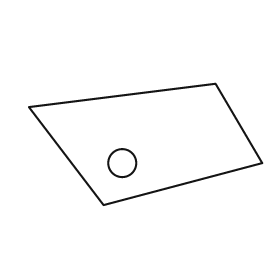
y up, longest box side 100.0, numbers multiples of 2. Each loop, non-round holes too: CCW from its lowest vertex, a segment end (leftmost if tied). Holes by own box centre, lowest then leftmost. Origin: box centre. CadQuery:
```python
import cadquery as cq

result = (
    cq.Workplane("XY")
    .moveTo(-18.0, -26.0)
    .lineTo(50.0, -8.0)
    .lineTo(30.0, 26.0)
    .lineTo(-50.0, 16.0)
    .close()
    .moveTo(-10.0, -8.0)
    .circle(6.0)
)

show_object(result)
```